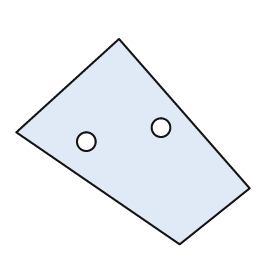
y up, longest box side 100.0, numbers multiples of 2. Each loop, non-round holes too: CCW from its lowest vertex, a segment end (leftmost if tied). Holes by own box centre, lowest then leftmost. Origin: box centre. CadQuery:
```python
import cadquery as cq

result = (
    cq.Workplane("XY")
    .moveTo(20.0, -44.0)
    .lineTo(50.0, -20.0)
    .lineTo(-6.0, 44.0)
    .lineTo(-50.0, 4.0)
    .close()
    .moveTo(-20.0, 0.0)
    .circle(4.0)
    .moveTo(12.0, 6.0)
    .circle(4.0)
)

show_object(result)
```